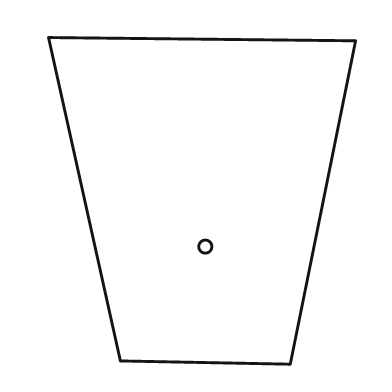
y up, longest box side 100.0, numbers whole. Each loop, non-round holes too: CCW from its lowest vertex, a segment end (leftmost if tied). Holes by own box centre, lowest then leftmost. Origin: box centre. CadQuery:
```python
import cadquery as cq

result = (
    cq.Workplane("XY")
    .moveTo(27.0, -50.0)
    .lineTo(47.0, 49.0)
    .lineTo(-47.0, 50.0)
    .lineTo(-25.0, -49.0)
    .close()
    .moveTo(1.0, -14.0)
    .circle(2.0)
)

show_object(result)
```